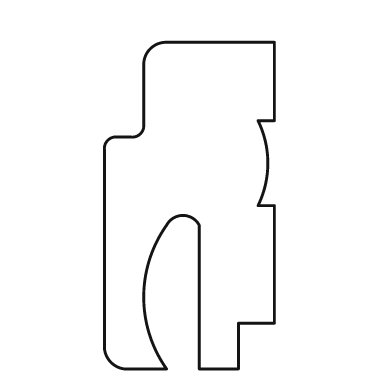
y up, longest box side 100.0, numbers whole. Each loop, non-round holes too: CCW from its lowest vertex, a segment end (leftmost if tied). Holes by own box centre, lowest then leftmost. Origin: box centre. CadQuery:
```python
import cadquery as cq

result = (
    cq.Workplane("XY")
    .moveTo(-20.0, -50.0)
    .lineTo(-7.0, -50.0)
    .threePointArc((-14.0, -28.0), (-7.0, -6.0))
    .threePointArc((-2.0, -3.0), (3.0, -6.0))
    .lineTo(3.0, -50.0)
    .lineTo(15.0, -50.0)
    .lineTo(15.0, -36.0)
    .lineTo(26.0, -36.0)
    .lineTo(26.0, 0.0)
    .lineTo(21.0, 0.0)
    .threePointArc((24.0, 13.0), (21.0, 26.0))
    .lineTo(26.0, 26.0)
    .lineTo(26.0, 50.0)
    .lineTo(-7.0, 50.0)
    .threePointArc((-12.0, 48.0), (-14.0, 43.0))
    .lineTo(-14.0, 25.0)
    .threePointArc((-15.0, 22.0), (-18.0, 21.0))
    .lineTo(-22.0, 21.0)
    .threePointArc((-25.0, 20.0), (-26.0, 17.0))
    .lineTo(-26.0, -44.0)
    .threePointArc((-24.0, -48.0), (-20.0, -50.0))
    .close()
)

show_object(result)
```